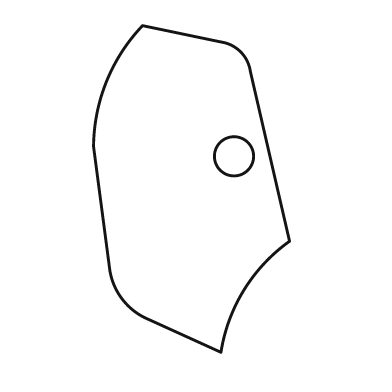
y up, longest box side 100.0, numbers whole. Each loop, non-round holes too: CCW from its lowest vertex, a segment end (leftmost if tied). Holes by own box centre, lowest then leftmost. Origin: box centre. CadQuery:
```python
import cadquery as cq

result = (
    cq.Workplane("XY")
    .moveTo(9.0, -50.0)
    .threePointArc((16.0, -31.0), (30.0, -16.0))
    .lineTo(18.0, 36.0)
    .threePointArc((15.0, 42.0), (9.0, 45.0))
    .lineTo(-15.0, 50.0)
    .threePointArc((-26.0, 33.0), (-30.0, 13.0))
    .lineTo(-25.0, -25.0)
    .threePointArc((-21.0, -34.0), (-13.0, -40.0))
    .close()
    .moveTo(13.0, 10.0)
    .circle(6.0)
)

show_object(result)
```